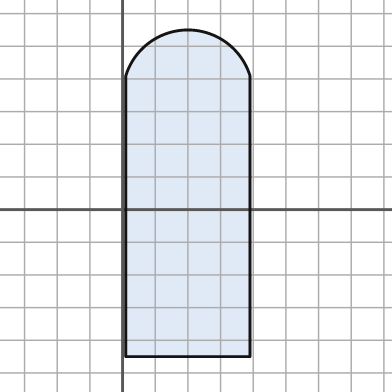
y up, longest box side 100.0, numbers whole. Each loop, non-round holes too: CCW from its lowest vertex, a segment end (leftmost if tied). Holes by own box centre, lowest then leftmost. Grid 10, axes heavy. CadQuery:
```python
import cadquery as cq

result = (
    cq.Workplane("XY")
    .moveTo(1.0, -45.0)
    .lineTo(39.0, -45.0)
    .lineTo(39.0, 41.0)
    .threePointArc((20.0, 55.0), (1.0, 41.0))
    .close()
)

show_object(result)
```